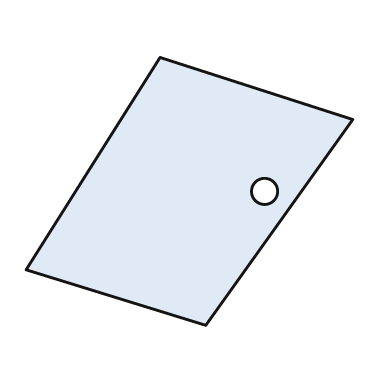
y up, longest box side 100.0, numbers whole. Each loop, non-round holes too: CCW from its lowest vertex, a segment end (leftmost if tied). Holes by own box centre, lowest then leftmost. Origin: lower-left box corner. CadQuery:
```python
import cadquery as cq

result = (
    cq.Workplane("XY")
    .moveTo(55.0, 0.0)
    .lineTo(100.0, 63.0)
    .lineTo(41.0, 82.0)
    .lineTo(0.0, 17.0)
    .close()
    .moveTo(73.0, 41.0)
    .circle(4.0)
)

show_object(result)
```